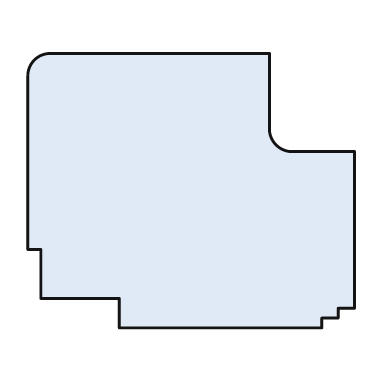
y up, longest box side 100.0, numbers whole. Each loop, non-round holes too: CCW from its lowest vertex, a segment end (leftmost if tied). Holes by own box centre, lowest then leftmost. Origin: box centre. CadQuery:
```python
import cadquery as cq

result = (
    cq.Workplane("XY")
    .moveTo(-22.0, -42.0)
    .lineTo(40.0, -42.0)
    .lineTo(40.0, -39.0)
    .lineTo(45.0, -39.0)
    .lineTo(45.0, -36.0)
    .lineTo(50.0, -36.0)
    .lineTo(50.0, 12.0)
    .lineTo(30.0, 12.0)
    .threePointArc((26.0, 14.0), (24.0, 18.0))
    .lineTo(24.0, 42.0)
    .lineTo(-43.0, 42.0)
    .threePointArc((-48.0, 40.0), (-50.0, 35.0))
    .lineTo(-50.0, -18.0)
    .lineTo(-46.0, -18.0)
    .lineTo(-46.0, -33.0)
    .lineTo(-22.0, -33.0)
    .close()
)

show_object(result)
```